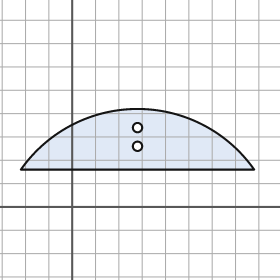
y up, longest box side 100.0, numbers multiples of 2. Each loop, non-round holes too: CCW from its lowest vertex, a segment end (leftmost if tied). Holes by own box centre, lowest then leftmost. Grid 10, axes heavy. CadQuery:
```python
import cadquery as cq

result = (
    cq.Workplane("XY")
    .moveTo(-22.0, 16.0)
    .lineTo(78.0, 16.0)
    .threePointArc((28.0, 42.0), (-22.0, 16.0))
    .close()
    .moveTo(28.0, 26.0)
    .circle(2.0)
    .moveTo(28.0, 34.0)
    .circle(2.0)
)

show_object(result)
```